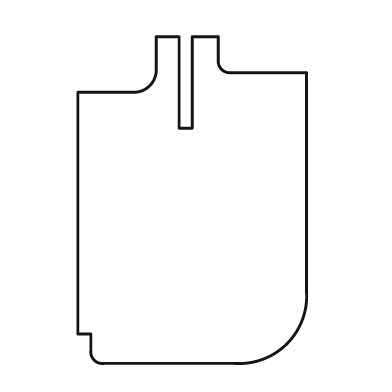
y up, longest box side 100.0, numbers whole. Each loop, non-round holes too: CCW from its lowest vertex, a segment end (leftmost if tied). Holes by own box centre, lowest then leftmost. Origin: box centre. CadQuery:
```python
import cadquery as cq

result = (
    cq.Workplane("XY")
    .moveTo(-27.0, -50.0)
    .lineTo(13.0, -50.0)
    .threePointArc((29.0, -44.0), (35.0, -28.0))
    .lineTo(35.0, 39.0)
    .lineTo(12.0, 39.0)
    .threePointArc((9.0, 40.0), (8.0, 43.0))
    .lineTo(8.0, 50.0)
    .lineTo(0.0, 50.0)
    .lineTo(0.0, 22.0)
    .lineTo(-4.0, 22.0)
    .lineTo(-4.0, 50.0)
    .lineTo(-11.0, 50.0)
    .lineTo(-11.0, 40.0)
    .threePointArc((-13.0, 35.0), (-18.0, 33.0))
    .lineTo(-35.0, 33.0)
    .lineTo(-35.0, -41.0)
    .lineTo(-31.0, -41.0)
    .lineTo(-31.0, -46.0)
    .threePointArc((-30.0, -49.0), (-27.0, -50.0))
    .close()
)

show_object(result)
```